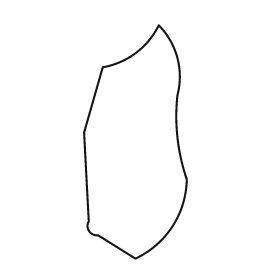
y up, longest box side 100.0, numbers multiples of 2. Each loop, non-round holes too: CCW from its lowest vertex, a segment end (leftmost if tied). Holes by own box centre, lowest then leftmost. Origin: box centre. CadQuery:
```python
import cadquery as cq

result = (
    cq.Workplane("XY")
    .moveTo(0.0, -50.0)
    .threePointArc((16.0, -36.0), (22.0, -16.0))
    .threePointArc((18.0, 2.0), (18.0, 20.0))
    .threePointArc((18.0, 36.0), (10.0, 50.0))
    .threePointArc((0.0, 38.0), (-14.0, 32.0))
    .lineTo(-22.0, 4.0)
    .lineTo(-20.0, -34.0)
    .threePointArc((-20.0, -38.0), (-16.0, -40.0))
    .close()
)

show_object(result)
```